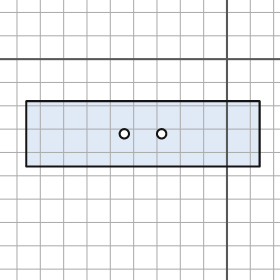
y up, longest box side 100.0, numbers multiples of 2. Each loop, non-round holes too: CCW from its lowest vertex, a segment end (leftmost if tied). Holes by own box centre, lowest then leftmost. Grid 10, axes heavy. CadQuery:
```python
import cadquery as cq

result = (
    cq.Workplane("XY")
    .moveTo(-86.0, -46.0)
    .lineTo(14.0, -46.0)
    .lineTo(14.0, -18.0)
    .lineTo(-86.0, -18.0)
    .close()
    .moveTo(-44.0, -32.0)
    .circle(2.0)
    .moveTo(-28.0, -32.0)
    .circle(2.0)
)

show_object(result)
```